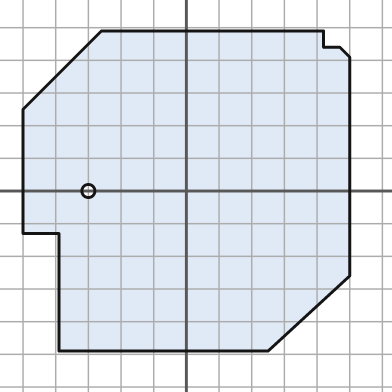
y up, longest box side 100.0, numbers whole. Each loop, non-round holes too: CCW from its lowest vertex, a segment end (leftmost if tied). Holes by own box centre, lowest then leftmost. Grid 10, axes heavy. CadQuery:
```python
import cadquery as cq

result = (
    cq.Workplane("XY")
    .moveTo(-39.0, -49.0)
    .lineTo(25.0, -49.0)
    .lineTo(50.0, -26.0)
    .lineTo(50.0, 41.0)
    .lineTo(47.0, 44.0)
    .lineTo(42.0, 44.0)
    .lineTo(42.0, 49.0)
    .lineTo(-26.0, 49.0)
    .lineTo(-50.0, 25.0)
    .lineTo(-50.0, -13.0)
    .lineTo(-39.0, -13.0)
    .close()
    .moveTo(-30.0, 0.0)
    .circle(2.0)
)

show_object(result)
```